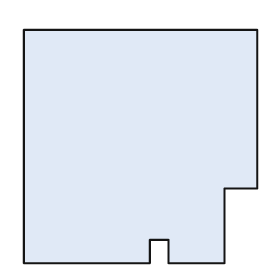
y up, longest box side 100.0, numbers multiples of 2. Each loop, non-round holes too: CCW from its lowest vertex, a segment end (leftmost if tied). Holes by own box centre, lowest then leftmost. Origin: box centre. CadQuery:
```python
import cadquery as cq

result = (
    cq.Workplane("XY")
    .moveTo(-50.0, -50.0)
    .lineTo(4.0, -50.0)
    .lineTo(4.0, -40.0)
    .lineTo(12.0, -40.0)
    .lineTo(12.0, -50.0)
    .lineTo(36.0, -50.0)
    .lineTo(36.0, -18.0)
    .lineTo(50.0, -18.0)
    .lineTo(50.0, 50.0)
    .lineTo(-50.0, 50.0)
    .close()
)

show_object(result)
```